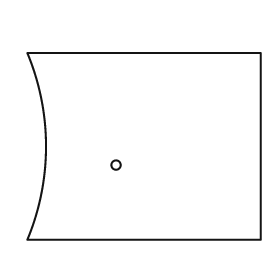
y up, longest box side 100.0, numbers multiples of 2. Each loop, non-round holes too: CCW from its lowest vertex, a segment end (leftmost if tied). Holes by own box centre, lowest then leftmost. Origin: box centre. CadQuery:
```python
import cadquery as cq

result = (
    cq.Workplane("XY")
    .moveTo(-50.0, -40.0)
    .lineTo(50.0, -40.0)
    .lineTo(50.0, 40.0)
    .lineTo(-50.0, 40.0)
    .threePointArc((-42.0, 0.0), (-50.0, -40.0))
    .close()
    .moveTo(-12.0, -8.0)
    .circle(2.0)
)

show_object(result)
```